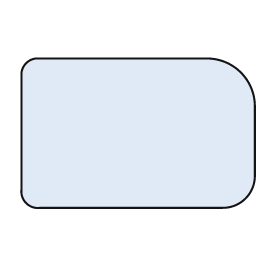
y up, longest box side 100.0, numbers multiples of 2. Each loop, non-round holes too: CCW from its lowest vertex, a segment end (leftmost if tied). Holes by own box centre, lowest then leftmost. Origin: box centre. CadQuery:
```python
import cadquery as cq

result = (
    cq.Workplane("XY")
    .moveTo(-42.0, -32.0)
    .lineTo(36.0, -32.0)
    .threePointArc((46.0, -28.0), (50.0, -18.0))
    .lineTo(50.0, 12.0)
    .threePointArc((44.0, 26.0), (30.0, 32.0))
    .lineTo(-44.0, 32.0)
    .threePointArc((-48.0, 30.0), (-50.0, 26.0))
    .lineTo(-50.0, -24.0)
    .threePointArc((-48.0, -30.0), (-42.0, -32.0))
    .close()
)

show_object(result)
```